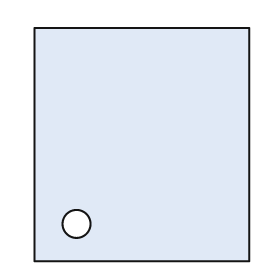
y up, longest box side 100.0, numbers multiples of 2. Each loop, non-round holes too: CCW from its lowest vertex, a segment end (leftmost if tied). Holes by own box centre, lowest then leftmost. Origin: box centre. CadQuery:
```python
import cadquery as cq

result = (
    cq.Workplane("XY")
    .moveTo(-46.0, -50.0)
    .lineTo(46.0, -50.0)
    .lineTo(46.0, 50.0)
    .lineTo(-46.0, 50.0)
    .close()
    .moveTo(-28.0, -34.0)
    .circle(6.0)
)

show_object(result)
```